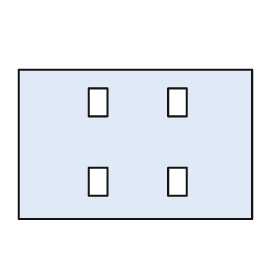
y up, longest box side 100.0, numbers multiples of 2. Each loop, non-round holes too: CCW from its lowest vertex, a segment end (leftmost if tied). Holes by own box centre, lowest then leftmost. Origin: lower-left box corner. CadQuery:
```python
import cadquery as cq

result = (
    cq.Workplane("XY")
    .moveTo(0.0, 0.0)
    .lineTo(100.0, 0.0)
    .lineTo(100.0, 64.0)
    .lineTo(0.0, 64.0)
    .close()
    .moveTo(30.0, 10.0)
    .lineTo(38.0, 10.0)
    .lineTo(38.0, 22.0)
    .lineTo(30.0, 22.0)
    .close()
    .moveTo(64.0, 10.0)
    .lineTo(72.0, 10.0)
    .lineTo(72.0, 22.0)
    .lineTo(64.0, 22.0)
    .close()
    .moveTo(30.0, 44.0)
    .lineTo(38.0, 44.0)
    .lineTo(38.0, 56.0)
    .lineTo(30.0, 56.0)
    .close()
    .moveTo(64.0, 44.0)
    .lineTo(72.0, 44.0)
    .lineTo(72.0, 56.0)
    .lineTo(64.0, 56.0)
    .close()
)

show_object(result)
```